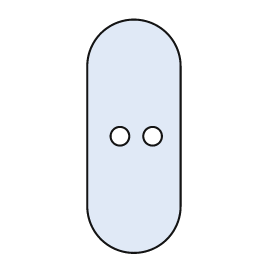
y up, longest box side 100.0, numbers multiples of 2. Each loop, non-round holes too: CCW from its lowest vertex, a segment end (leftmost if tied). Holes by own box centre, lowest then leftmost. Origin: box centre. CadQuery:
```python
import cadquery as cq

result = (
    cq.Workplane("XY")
    .moveTo(-20.0, -30.0)
    .threePointArc((0.0, -50.0), (20.0, -30.0))
    .lineTo(20.0, 30.0)
    .threePointArc((0.0, 50.0), (-20.0, 30.0))
    .close()
    .moveTo(-6.0, 0.0)
    .circle(4.0)
    .moveTo(8.0, 0.0)
    .circle(4.0)
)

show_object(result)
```